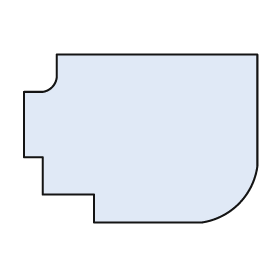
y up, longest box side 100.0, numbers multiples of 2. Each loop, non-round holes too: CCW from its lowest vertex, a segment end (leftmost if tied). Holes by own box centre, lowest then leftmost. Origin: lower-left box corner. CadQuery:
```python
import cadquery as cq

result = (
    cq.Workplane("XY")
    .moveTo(30.0, 0.0)
    .lineTo(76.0, 0.0)
    .threePointArc((92.0, 8.0), (100.0, 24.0))
    .lineTo(100.0, 72.0)
    .lineTo(14.0, 72.0)
    .lineTo(14.0, 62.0)
    .threePointArc((12.0, 58.0), (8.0, 56.0))
    .lineTo(0.0, 56.0)
    .lineTo(0.0, 28.0)
    .lineTo(8.0, 28.0)
    .lineTo(8.0, 12.0)
    .lineTo(30.0, 12.0)
    .close()
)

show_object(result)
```